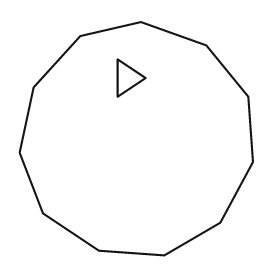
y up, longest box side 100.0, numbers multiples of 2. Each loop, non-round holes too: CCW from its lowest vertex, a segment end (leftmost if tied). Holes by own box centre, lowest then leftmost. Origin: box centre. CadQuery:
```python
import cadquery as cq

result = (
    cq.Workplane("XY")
    .moveTo(12.0, -50.0)
    .lineTo(36.0, -36.0)
    .lineTo(50.0, -10.0)
    .lineTo(48.0, 18.0)
    .lineTo(30.0, 40.0)
    .lineTo(2.0, 50.0)
    .lineTo(-24.0, 44.0)
    .lineTo(-44.0, 22.0)
    .lineTo(-50.0, -6.0)
    .lineTo(-40.0, -32.0)
    .lineTo(-16.0, -48.0)
    .close()
    .moveTo(-8.0, 18.0)
    .lineTo(4.0, 26.0)
    .lineTo(-8.0, 34.0)
    .close()
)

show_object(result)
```